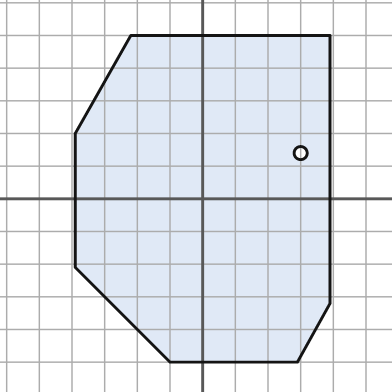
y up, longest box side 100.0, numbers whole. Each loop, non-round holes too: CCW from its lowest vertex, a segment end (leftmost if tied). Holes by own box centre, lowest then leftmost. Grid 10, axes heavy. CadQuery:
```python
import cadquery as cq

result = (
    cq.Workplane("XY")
    .moveTo(-10.0, -50.0)
    .lineTo(29.0, -50.0)
    .lineTo(39.0, -32.0)
    .lineTo(39.0, 50.0)
    .lineTo(-22.0, 50.0)
    .lineTo(-39.0, 20.0)
    .lineTo(-39.0, -21.0)
    .close()
    .moveTo(30.0, 14.0)
    .circle(2.0)
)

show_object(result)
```